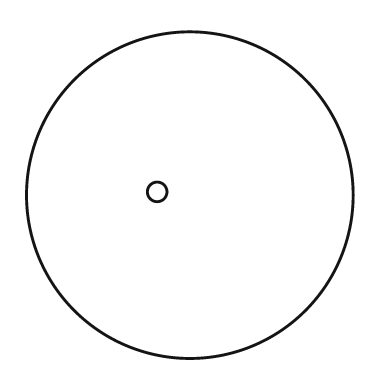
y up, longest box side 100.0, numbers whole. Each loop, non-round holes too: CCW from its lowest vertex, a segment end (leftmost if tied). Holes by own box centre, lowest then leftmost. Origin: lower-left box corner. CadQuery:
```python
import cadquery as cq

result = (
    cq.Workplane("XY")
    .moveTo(50.0, 50.0)
    .circle(50.0)
    .moveTo(40.0, 51.0)
    .circle(3.0)
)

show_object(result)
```